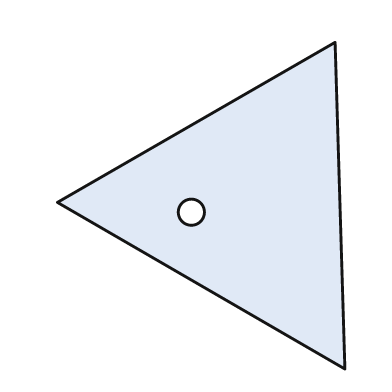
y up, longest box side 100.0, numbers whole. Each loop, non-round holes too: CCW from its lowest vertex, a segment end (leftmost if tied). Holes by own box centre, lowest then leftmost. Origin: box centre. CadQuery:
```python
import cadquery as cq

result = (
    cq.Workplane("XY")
    .moveTo(44.0, -50.0)
    .lineTo(41.0, 50.0)
    .lineTo(-44.0, 1.0)
    .close()
    .moveTo(-3.0, -2.0)
    .circle(4.0)
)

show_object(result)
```